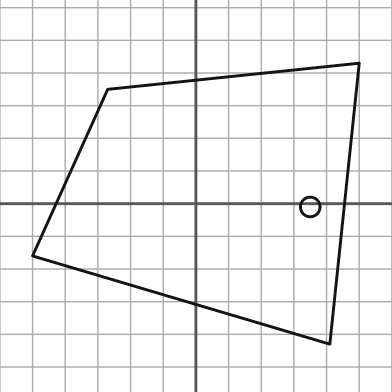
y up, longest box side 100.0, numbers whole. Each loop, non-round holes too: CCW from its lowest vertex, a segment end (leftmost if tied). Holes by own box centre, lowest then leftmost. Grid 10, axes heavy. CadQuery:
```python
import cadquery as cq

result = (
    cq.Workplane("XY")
    .moveTo(41.0, -43.0)
    .lineTo(50.0, 43.0)
    .lineTo(-27.0, 35.0)
    .lineTo(-50.0, -16.0)
    .close()
    .moveTo(35.0, -1.0)
    .circle(3.0)
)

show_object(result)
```